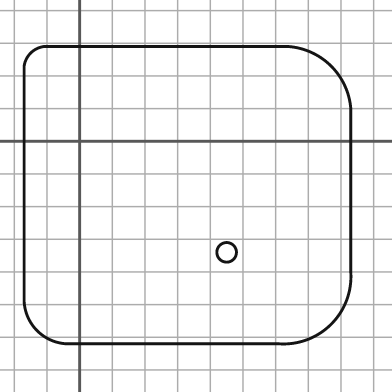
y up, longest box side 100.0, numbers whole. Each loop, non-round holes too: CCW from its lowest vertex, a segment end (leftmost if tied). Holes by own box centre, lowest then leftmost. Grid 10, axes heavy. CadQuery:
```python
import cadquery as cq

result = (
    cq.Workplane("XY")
    .moveTo(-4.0, -62.0)
    .lineTo(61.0, -62.0)
    .threePointArc((77.0, -56.0), (83.0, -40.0))
    .lineTo(83.0, 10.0)
    .threePointArc((77.0, 23.0), (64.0, 29.0))
    .lineTo(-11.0, 29.0)
    .threePointArc((-15.0, 27.0), (-17.0, 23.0))
    .lineTo(-17.0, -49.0)
    .threePointArc((-13.0, -58.0), (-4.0, -62.0))
    .close()
    .moveTo(45.0, -34.0)
    .circle(3.0)
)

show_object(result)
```